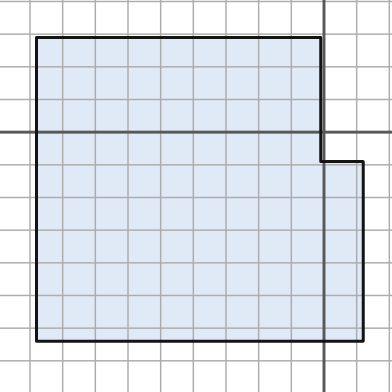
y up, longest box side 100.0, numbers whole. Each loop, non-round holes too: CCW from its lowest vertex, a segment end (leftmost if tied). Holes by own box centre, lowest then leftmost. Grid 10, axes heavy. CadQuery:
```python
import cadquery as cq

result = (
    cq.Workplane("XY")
    .moveTo(-88.0, -64.0)
    .lineTo(12.0, -64.0)
    .lineTo(12.0, -9.0)
    .lineTo(-1.0, -9.0)
    .lineTo(-1.0, 29.0)
    .lineTo(-88.0, 29.0)
    .close()
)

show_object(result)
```